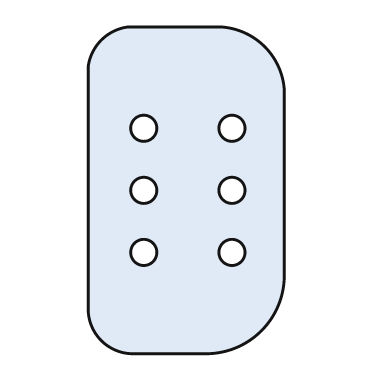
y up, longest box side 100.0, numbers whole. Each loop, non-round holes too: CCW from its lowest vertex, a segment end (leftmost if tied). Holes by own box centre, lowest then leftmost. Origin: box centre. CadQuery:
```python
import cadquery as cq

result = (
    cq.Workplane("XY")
    .moveTo(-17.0, -50.0)
    .lineTo(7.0, -50.0)
    .threePointArc((23.0, -43.0), (30.0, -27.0))
    .lineTo(30.0, 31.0)
    .threePointArc((24.0, 44.0), (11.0, 50.0))
    .lineTo(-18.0, 50.0)
    .threePointArc((-26.0, 46.0), (-30.0, 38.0))
    .lineTo(-30.0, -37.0)
    .threePointArc((-26.0, -46.0), (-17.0, -50.0))
    .close()
    .moveTo(-13.0, -19.0)
    .circle(4.0)
    .moveTo(14.0, -19.0)
    .circle(4.0)
    .moveTo(-13.0, 0.0)
    .circle(4.0)
    .moveTo(14.0, 0.0)
    .circle(4.0)
    .moveTo(-13.0, 19.0)
    .circle(4.0)
    .moveTo(14.0, 19.0)
    .circle(4.0)
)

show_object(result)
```